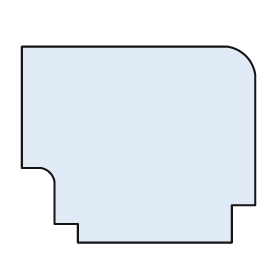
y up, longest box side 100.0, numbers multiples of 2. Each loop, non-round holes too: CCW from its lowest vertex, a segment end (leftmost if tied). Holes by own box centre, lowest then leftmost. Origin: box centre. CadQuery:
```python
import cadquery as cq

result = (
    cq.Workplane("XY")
    .moveTo(-26.0, -42.0)
    .lineTo(40.0, -42.0)
    .lineTo(40.0, -26.0)
    .lineTo(50.0, -26.0)
    .lineTo(50.0, 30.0)
    .threePointArc((46.0, 38.0), (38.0, 42.0))
    .lineTo(-50.0, 42.0)
    .lineTo(-50.0, -10.0)
    .lineTo(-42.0, -10.0)
    .threePointArc((-38.0, -12.0), (-36.0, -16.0))
    .lineTo(-36.0, -34.0)
    .lineTo(-26.0, -34.0)
    .close()
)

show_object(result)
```